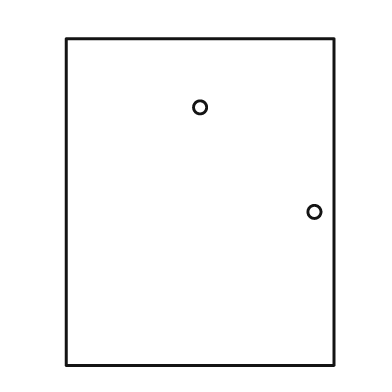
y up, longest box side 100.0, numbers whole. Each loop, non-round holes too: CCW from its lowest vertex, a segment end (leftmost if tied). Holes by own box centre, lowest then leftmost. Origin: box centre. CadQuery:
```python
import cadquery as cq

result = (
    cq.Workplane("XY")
    .moveTo(-41.0, -50.0)
    .lineTo(41.0, -50.0)
    .lineTo(41.0, 50.0)
    .lineTo(-41.0, 50.0)
    .close()
    .moveTo(35.0, -3.0)
    .circle(2.0)
    .moveTo(0.0, 29.0)
    .circle(2.0)
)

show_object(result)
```